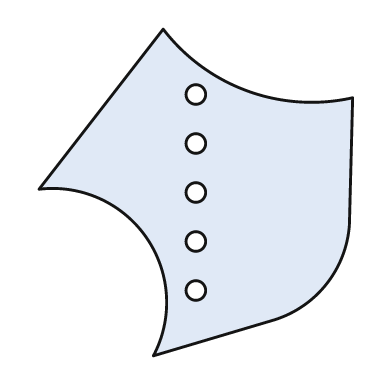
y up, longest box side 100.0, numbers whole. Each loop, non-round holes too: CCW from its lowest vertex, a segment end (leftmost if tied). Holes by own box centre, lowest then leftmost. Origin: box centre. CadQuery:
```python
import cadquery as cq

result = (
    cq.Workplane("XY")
    .moveTo(-13.0, -50.0)
    .lineTo(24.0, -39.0)
    .threePointArc((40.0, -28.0), (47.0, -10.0))
    .lineTo(48.0, 29.0)
    .threePointArc((16.0, 31.0), (-10.0, 50.0))
    .lineTo(-48.0, 1.0)
    .threePointArc((-15.0, -14.0), (-13.0, -50.0))
    .close()
    .moveTo(0.0, -30.0)
    .circle(3.0)
    .moveTo(0.0, -15.0)
    .circle(3.0)
    .moveTo(0.0, 0.0)
    .circle(3.0)
    .moveTo(0.0, 15.0)
    .circle(3.0)
    .moveTo(0.0, 30.0)
    .circle(3.0)
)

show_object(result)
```